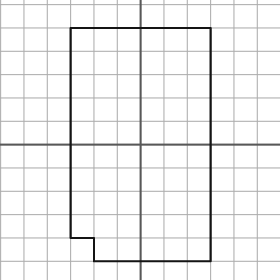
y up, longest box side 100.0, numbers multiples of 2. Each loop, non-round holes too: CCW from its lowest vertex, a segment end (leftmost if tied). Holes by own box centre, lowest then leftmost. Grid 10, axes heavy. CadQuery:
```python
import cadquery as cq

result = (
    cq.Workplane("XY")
    .moveTo(-20.0, -50.0)
    .lineTo(30.0, -50.0)
    .lineTo(30.0, 50.0)
    .lineTo(-30.0, 50.0)
    .lineTo(-30.0, -40.0)
    .lineTo(-20.0, -40.0)
    .close()
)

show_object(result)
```